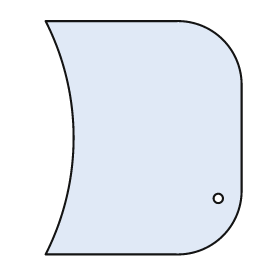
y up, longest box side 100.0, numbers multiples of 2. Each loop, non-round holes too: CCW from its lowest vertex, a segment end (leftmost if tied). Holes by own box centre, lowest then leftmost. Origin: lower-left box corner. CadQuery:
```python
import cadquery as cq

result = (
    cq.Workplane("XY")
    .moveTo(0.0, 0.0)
    .lineTo(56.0, 0.0)
    .threePointArc((76.0, 8.0), (84.0, 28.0))
    .lineTo(84.0, 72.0)
    .threePointArc((76.0, 92.0), (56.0, 100.0))
    .lineTo(0.0, 100.0)
    .threePointArc((12.0, 50.0), (0.0, 0.0))
    .close()
    .moveTo(74.0, 24.0)
    .circle(2.0)
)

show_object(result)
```